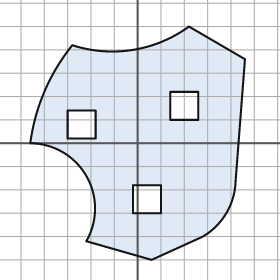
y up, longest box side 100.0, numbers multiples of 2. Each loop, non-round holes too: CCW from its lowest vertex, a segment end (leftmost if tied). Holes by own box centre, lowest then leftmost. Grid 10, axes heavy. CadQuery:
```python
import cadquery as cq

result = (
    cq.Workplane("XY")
    .moveTo(6.0, -50.0)
    .lineTo(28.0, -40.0)
    .threePointArc((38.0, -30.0), (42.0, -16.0))
    .lineTo(46.0, 36.0)
    .lineTo(22.0, 50.0)
    .threePointArc((-2.0, 40.0), (-28.0, 42.0))
    .threePointArc((-40.0, 22.0), (-46.0, 0.0))
    .threePointArc((-22.0, -14.0), (-22.0, -42.0))
    .close()
    .moveTo(-2.0, -30.0)
    .lineTo(10.0, -30.0)
    .lineTo(10.0, -18.0)
    .lineTo(-2.0, -18.0)
    .close()
    .moveTo(-30.0, 2.0)
    .lineTo(-18.0, 2.0)
    .lineTo(-18.0, 14.0)
    .lineTo(-30.0, 14.0)
    .close()
    .moveTo(14.0, 10.0)
    .lineTo(26.0, 10.0)
    .lineTo(26.0, 22.0)
    .lineTo(14.0, 22.0)
    .close()
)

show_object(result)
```